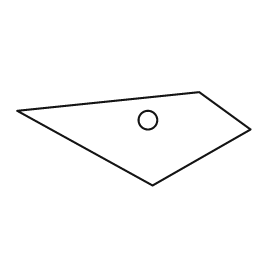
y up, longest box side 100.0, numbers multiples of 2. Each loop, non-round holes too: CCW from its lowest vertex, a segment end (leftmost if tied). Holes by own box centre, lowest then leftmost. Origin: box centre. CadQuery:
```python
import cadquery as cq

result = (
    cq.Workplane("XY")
    .moveTo(8.0, -20.0)
    .lineTo(50.0, 4.0)
    .lineTo(28.0, 20.0)
    .lineTo(-50.0, 12.0)
    .close()
    .moveTo(6.0, 8.0)
    .circle(4.0)
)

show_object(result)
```